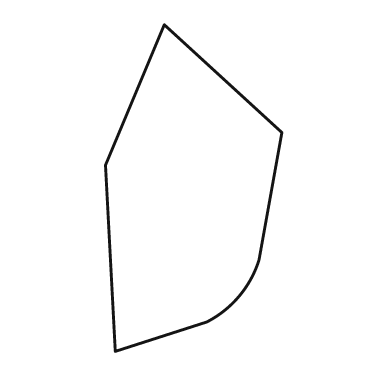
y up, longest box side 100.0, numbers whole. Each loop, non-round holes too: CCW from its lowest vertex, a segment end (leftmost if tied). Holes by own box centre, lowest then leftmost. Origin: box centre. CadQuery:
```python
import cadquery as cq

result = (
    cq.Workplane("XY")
    .moveTo(-24.0, -50.0)
    .lineTo(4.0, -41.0)
    .threePointArc((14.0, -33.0), (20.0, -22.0))
    .lineTo(27.0, 17.0)
    .lineTo(-9.0, 50.0)
    .lineTo(-27.0, 7.0)
    .close()
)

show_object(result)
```